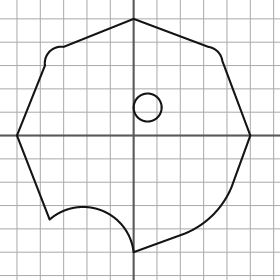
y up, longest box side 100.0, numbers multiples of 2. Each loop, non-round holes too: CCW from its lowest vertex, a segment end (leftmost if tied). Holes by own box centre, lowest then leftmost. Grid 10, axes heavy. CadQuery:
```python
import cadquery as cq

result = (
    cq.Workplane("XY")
    .moveTo(0.0, -50.0)
    .lineTo(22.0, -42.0)
    .threePointArc((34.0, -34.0), (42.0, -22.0))
    .lineTo(50.0, 0.0)
    .lineTo(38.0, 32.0)
    .threePointArc((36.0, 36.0), (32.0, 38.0))
    .lineTo(0.0, 50.0)
    .lineTo(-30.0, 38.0)
    .threePointArc((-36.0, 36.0), (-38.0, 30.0))
    .lineTo(-50.0, 0.0)
    .lineTo(-36.0, -36.0)
    .threePointArc((-14.0, -32.0), (0.0, -50.0))
    .close()
    .moveTo(6.0, 12.0)
    .circle(6.0)
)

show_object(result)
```